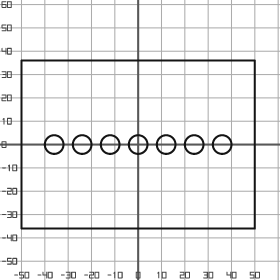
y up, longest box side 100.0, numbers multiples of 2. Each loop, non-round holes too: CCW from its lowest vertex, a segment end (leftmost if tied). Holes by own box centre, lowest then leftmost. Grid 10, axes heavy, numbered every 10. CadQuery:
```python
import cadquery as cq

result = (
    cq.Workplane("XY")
    .moveTo(-50.0, -36.0)
    .lineTo(50.0, -36.0)
    .lineTo(50.0, 36.0)
    .lineTo(-50.0, 36.0)
    .close()
    .moveTo(-36.0, 0.0)
    .circle(4.0)
    .moveTo(-24.0, 0.0)
    .circle(4.0)
    .moveTo(-12.0, 0.0)
    .circle(4.0)
    .moveTo(0.0, 0.0)
    .circle(4.0)
    .moveTo(12.0, 0.0)
    .circle(4.0)
    .moveTo(24.0, 0.0)
    .circle(4.0)
    .moveTo(36.0, 0.0)
    .circle(4.0)
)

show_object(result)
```